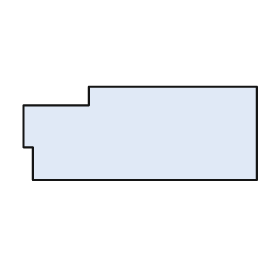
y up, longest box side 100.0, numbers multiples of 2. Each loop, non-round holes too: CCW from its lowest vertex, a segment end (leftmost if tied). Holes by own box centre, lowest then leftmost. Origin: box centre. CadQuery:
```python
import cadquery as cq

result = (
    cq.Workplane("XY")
    .moveTo(-46.0, -20.0)
    .lineTo(50.0, -20.0)
    .lineTo(50.0, 20.0)
    .lineTo(-22.0, 20.0)
    .lineTo(-22.0, 12.0)
    .lineTo(-50.0, 12.0)
    .lineTo(-50.0, -6.0)
    .lineTo(-46.0, -6.0)
    .close()
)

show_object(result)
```